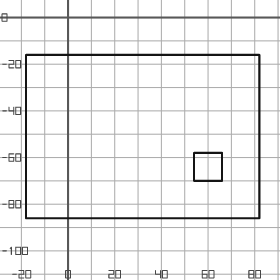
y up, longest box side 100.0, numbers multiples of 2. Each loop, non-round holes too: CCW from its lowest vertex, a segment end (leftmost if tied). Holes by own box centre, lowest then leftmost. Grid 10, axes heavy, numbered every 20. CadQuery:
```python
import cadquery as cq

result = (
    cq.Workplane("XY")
    .moveTo(-18.0, -86.0)
    .lineTo(82.0, -86.0)
    .lineTo(82.0, -16.0)
    .lineTo(-18.0, -16.0)
    .close()
    .moveTo(54.0, -70.0)
    .lineTo(66.0, -70.0)
    .lineTo(66.0, -58.0)
    .lineTo(54.0, -58.0)
    .close()
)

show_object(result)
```